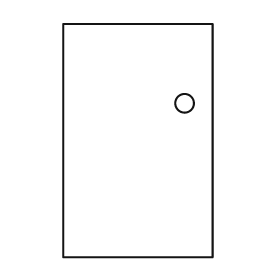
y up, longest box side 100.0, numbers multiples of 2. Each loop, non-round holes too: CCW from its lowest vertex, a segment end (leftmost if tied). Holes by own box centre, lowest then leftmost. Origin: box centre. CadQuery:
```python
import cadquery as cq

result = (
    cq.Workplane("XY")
    .moveTo(-32.0, -50.0)
    .lineTo(32.0, -50.0)
    .lineTo(32.0, 50.0)
    .lineTo(-32.0, 50.0)
    .close()
    .moveTo(20.0, 16.0)
    .circle(4.0)
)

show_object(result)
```